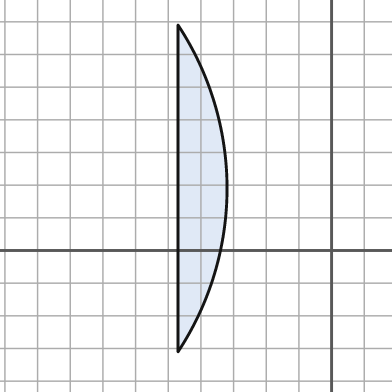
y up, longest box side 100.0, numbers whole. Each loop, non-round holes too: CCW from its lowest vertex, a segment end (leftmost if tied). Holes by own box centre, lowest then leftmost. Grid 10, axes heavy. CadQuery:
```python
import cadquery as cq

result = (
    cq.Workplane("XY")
    .moveTo(-47.0, -31.0)
    .threePointArc((-32.0, 19.0), (-47.0, 69.0))
    .close()
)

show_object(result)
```